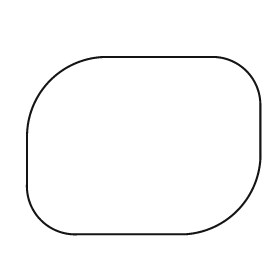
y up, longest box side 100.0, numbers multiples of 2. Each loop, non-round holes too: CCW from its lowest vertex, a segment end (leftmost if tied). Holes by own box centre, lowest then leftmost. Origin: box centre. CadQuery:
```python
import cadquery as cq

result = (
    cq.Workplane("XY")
    .moveTo(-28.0, -38.0)
    .lineTo(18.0, -38.0)
    .threePointArc((40.0, -28.0), (50.0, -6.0))
    .lineTo(50.0, 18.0)
    .threePointArc((44.0, 32.0), (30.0, 38.0))
    .lineTo(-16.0, 38.0)
    .threePointArc((-40.0, 28.0), (-50.0, 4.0))
    .lineTo(-50.0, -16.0)
    .threePointArc((-44.0, -32.0), (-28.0, -38.0))
    .close()
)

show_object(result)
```